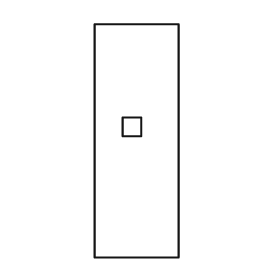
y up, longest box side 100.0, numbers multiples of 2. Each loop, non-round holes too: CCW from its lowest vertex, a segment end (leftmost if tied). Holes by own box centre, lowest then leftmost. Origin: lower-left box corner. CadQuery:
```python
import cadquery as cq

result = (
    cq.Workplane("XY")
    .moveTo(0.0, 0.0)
    .lineTo(36.0, 0.0)
    .lineTo(36.0, 100.0)
    .lineTo(0.0, 100.0)
    .close()
    .moveTo(12.0, 52.0)
    .lineTo(20.0, 52.0)
    .lineTo(20.0, 60.0)
    .lineTo(12.0, 60.0)
    .close()
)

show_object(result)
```